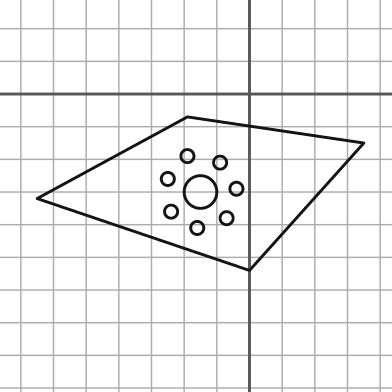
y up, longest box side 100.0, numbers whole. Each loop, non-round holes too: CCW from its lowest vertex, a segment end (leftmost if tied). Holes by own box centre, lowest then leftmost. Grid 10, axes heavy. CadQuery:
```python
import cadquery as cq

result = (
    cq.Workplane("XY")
    .moveTo(0.0, -54.0)
    .lineTo(35.0, -15.0)
    .lineTo(-19.0, -7.0)
    .lineTo(-65.0, -32.0)
    .close()
    .moveTo(-16.0, -41.0)
    .circle(2.0)
    .moveTo(-7.0, -38.0)
    .circle(2.0)
    .moveTo(-24.0, -36.0)
    .circle(2.0)
    .moveTo(-15.0, -30.0)
    .circle(5.0)
    .moveTo(-4.0, -29.0)
    .circle(2.0)
    .moveTo(-25.0, -26.0)
    .circle(2.0)
    .moveTo(-9.0, -21.0)
    .circle(2.0)
    .moveTo(-19.0, -19.0)
    .circle(2.0)
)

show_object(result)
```